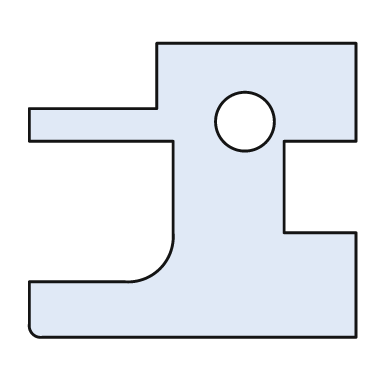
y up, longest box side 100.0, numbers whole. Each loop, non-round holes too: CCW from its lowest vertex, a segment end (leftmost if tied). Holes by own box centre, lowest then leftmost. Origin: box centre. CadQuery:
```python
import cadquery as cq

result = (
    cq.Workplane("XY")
    .moveTo(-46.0, -45.0)
    .lineTo(50.0, -45.0)
    .lineTo(50.0, -13.0)
    .lineTo(28.0, -13.0)
    .lineTo(28.0, 15.0)
    .lineTo(50.0, 15.0)
    .lineTo(50.0, 45.0)
    .lineTo(-11.0, 45.0)
    .lineTo(-11.0, 25.0)
    .lineTo(-50.0, 25.0)
    .lineTo(-50.0, 15.0)
    .lineTo(-6.0, 15.0)
    .lineTo(-6.0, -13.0)
    .threePointArc((-10.0, -24.0), (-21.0, -28.0))
    .lineTo(-50.0, -28.0)
    .lineTo(-50.0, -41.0)
    .threePointArc((-49.0, -44.0), (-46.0, -45.0))
    .close()
    .moveTo(16.0, 21.0)
    .circle(9.0)
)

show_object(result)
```